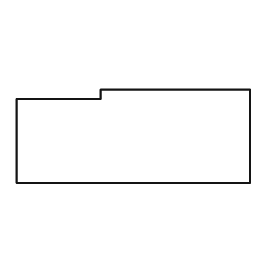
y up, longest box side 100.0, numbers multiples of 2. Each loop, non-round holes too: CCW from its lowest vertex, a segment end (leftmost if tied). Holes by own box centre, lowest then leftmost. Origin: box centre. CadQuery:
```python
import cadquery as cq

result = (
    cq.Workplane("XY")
    .moveTo(-50.0, -20.0)
    .lineTo(50.0, -20.0)
    .lineTo(50.0, 20.0)
    .lineTo(-14.0, 20.0)
    .lineTo(-14.0, 16.0)
    .lineTo(-50.0, 16.0)
    .close()
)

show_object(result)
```